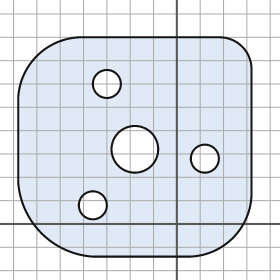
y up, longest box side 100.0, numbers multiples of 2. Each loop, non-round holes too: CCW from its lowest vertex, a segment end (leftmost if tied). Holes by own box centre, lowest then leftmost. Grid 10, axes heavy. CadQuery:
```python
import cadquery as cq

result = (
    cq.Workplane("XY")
    .moveTo(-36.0, -14.0)
    .lineTo(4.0, -14.0)
    .threePointArc((24.0, -6.0), (32.0, 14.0))
    .lineTo(32.0, 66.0)
    .threePointArc((28.0, 76.0), (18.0, 80.0))
    .lineTo(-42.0, 80.0)
    .threePointArc((-60.0, 72.0), (-68.0, 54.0))
    .lineTo(-68.0, 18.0)
    .threePointArc((-58.0, -4.0), (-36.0, -14.0))
    .close()
    .moveTo(-36.0, 8.0)
    .circle(6.0)
    .moveTo(12.0, 28.0)
    .circle(6.0)
    .moveTo(-18.0, 32.0)
    .circle(10.0)
    .moveTo(-30.0, 60.0)
    .circle(6.0)
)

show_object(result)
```